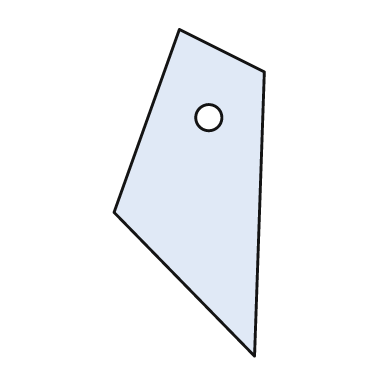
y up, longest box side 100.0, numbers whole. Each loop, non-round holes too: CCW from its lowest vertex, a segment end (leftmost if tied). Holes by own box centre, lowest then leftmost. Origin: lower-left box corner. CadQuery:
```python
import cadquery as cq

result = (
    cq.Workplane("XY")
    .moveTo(43.0, 0.0)
    .lineTo(46.0, 87.0)
    .lineTo(20.0, 100.0)
    .lineTo(0.0, 44.0)
    .close()
    .moveTo(29.0, 73.0)
    .circle(4.0)
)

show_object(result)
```